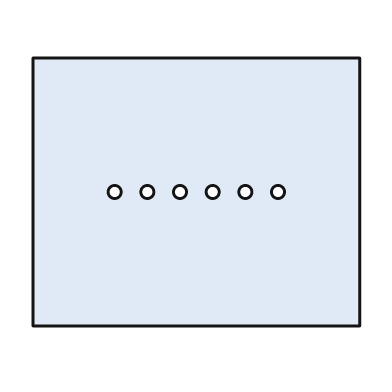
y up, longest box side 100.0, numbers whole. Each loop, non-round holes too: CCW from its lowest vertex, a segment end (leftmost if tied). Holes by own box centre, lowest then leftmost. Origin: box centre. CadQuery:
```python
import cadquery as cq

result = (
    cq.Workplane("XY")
    .moveTo(-50.0, -41.0)
    .lineTo(50.0, -41.0)
    .lineTo(50.0, 41.0)
    .lineTo(-50.0, 41.0)
    .close()
    .moveTo(-25.0, 0.0)
    .circle(2.0)
    .moveTo(-15.0, 0.0)
    .circle(2.0)
    .moveTo(-5.0, 0.0)
    .circle(2.0)
    .moveTo(5.0, 0.0)
    .circle(2.0)
    .moveTo(15.0, 0.0)
    .circle(2.0)
    .moveTo(25.0, 0.0)
    .circle(2.0)
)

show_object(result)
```